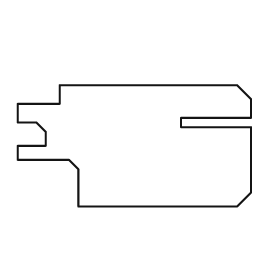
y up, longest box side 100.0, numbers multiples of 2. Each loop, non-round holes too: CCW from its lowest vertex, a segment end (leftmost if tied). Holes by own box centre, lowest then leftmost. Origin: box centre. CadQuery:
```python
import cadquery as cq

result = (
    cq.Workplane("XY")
    .moveTo(-24.0, -26.0)
    .lineTo(44.0, -26.0)
    .lineTo(50.0, -20.0)
    .lineTo(50.0, 8.0)
    .lineTo(20.0, 8.0)
    .lineTo(20.0, 12.0)
    .lineTo(50.0, 12.0)
    .lineTo(50.0, 20.0)
    .lineTo(44.0, 26.0)
    .lineTo(-32.0, 26.0)
    .lineTo(-32.0, 18.0)
    .lineTo(-50.0, 18.0)
    .lineTo(-50.0, 10.0)
    .lineTo(-42.0, 10.0)
    .lineTo(-38.0, 6.0)
    .lineTo(-38.0, 0.0)
    .lineTo(-50.0, 0.0)
    .lineTo(-50.0, -6.0)
    .lineTo(-28.0, -6.0)
    .lineTo(-24.0, -10.0)
    .close()
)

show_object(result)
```